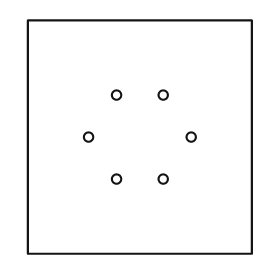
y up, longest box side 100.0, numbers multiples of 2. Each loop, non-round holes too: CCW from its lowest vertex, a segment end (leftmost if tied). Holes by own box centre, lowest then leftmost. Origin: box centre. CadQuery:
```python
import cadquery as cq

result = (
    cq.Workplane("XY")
    .moveTo(-48.0, -50.0)
    .lineTo(48.0, -50.0)
    .lineTo(48.0, 50.0)
    .lineTo(-48.0, 50.0)
    .close()
    .moveTo(-10.0, -18.0)
    .circle(2.0)
    .moveTo(10.0, -18.0)
    .circle(2.0)
    .moveTo(-22.0, 0.0)
    .circle(2.0)
    .moveTo(22.0, 0.0)
    .circle(2.0)
    .moveTo(-10.0, 18.0)
    .circle(2.0)
    .moveTo(10.0, 18.0)
    .circle(2.0)
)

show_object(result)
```